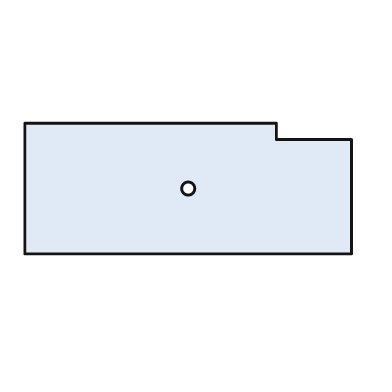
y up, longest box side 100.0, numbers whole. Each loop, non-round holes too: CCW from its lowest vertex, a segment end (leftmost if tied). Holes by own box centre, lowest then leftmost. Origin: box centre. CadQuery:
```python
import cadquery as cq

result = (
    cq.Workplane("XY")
    .moveTo(-50.0, -20.0)
    .lineTo(50.0, -20.0)
    .lineTo(50.0, 15.0)
    .lineTo(27.0, 15.0)
    .lineTo(27.0, 20.0)
    .lineTo(-50.0, 20.0)
    .close()
    .moveTo(0.0, 0.0)
    .circle(2.0)
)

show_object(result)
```